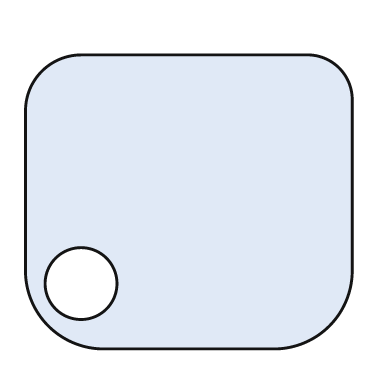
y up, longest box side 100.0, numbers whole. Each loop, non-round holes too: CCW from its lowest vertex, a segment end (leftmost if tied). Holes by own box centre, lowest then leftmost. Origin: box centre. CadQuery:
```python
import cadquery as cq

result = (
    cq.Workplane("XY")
    .moveTo(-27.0, -45.0)
    .lineTo(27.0, -45.0)
    .threePointArc((43.0, -38.0), (50.0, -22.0))
    .lineTo(50.0, 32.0)
    .threePointArc((46.0, 41.0), (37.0, 45.0))
    .lineTo(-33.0, 45.0)
    .threePointArc((-45.0, 40.0), (-50.0, 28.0))
    .lineTo(-50.0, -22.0)
    .threePointArc((-43.0, -38.0), (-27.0, -45.0))
    .close()
    .moveTo(-33.0, -25.0)
    .circle(11.0)
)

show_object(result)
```